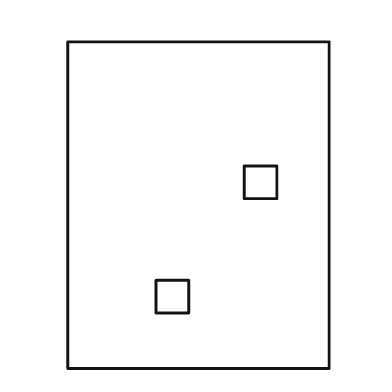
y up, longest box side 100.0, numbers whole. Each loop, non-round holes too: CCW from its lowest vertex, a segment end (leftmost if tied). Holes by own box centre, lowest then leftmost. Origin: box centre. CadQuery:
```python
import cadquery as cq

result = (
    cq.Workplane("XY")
    .moveTo(-40.0, -50.0)
    .lineTo(40.0, -50.0)
    .lineTo(40.0, 50.0)
    .lineTo(-40.0, 50.0)
    .close()
    .moveTo(-13.0, -33.0)
    .lineTo(-3.0, -33.0)
    .lineTo(-3.0, -23.0)
    .lineTo(-13.0, -23.0)
    .close()
    .moveTo(14.0, 2.0)
    .lineTo(24.0, 2.0)
    .lineTo(24.0, 12.0)
    .lineTo(14.0, 12.0)
    .close()
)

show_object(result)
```